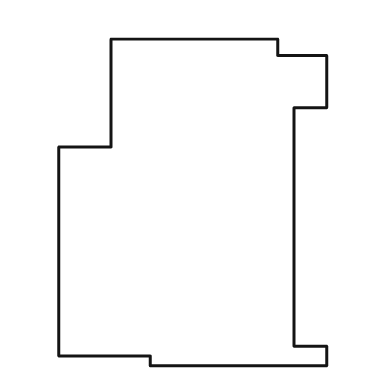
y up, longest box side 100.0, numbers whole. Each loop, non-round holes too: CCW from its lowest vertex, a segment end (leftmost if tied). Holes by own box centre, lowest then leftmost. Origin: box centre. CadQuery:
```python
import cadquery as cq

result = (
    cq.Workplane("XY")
    .moveTo(-13.0, -50.0)
    .lineTo(41.0, -50.0)
    .lineTo(41.0, -44.0)
    .lineTo(31.0, -44.0)
    .lineTo(31.0, 29.0)
    .lineTo(41.0, 29.0)
    .lineTo(41.0, 45.0)
    .lineTo(26.0, 45.0)
    .lineTo(26.0, 50.0)
    .lineTo(-25.0, 50.0)
    .lineTo(-25.0, 17.0)
    .lineTo(-41.0, 17.0)
    .lineTo(-41.0, -47.0)
    .lineTo(-13.0, -47.0)
    .close()
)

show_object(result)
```